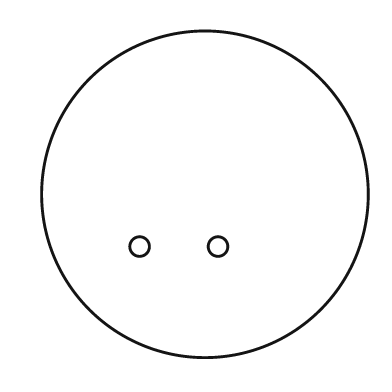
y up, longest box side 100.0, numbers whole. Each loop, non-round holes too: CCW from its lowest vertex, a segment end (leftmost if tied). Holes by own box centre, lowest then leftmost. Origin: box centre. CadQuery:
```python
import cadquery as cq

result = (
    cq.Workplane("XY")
    .moveTo(0.0, 0.0)
    .circle(50.0)
    .moveTo(-20.0, -16.0)
    .circle(3.0)
    .moveTo(4.0, -16.0)
    .circle(3.0)
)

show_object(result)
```